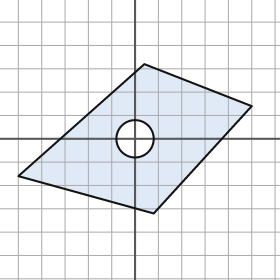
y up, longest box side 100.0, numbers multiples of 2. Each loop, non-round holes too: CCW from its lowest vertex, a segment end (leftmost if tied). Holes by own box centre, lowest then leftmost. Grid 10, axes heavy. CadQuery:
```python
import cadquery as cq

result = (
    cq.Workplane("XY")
    .moveTo(8.0, -32.0)
    .lineTo(50.0, 14.0)
    .lineTo(4.0, 32.0)
    .lineTo(-50.0, -16.0)
    .close()
    .moveTo(0.0, 0.0)
    .circle(8.0)
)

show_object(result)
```